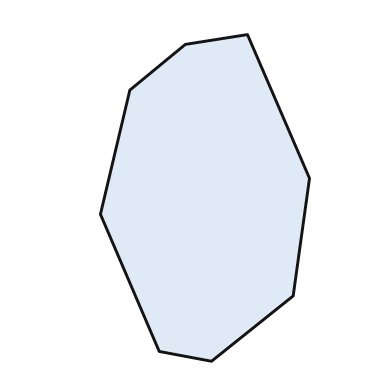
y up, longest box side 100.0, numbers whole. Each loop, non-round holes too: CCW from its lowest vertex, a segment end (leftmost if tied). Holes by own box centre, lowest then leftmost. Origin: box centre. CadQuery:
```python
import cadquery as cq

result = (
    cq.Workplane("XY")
    .moveTo(2.0, -50.0)
    .lineTo(27.0, -30.0)
    .lineTo(32.0, 6.0)
    .lineTo(13.0, 50.0)
    .lineTo(-6.0, 47.0)
    .lineTo(-23.0, 33.0)
    .lineTo(-32.0, -5.0)
    .lineTo(-14.0, -47.0)
    .close()
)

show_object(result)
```